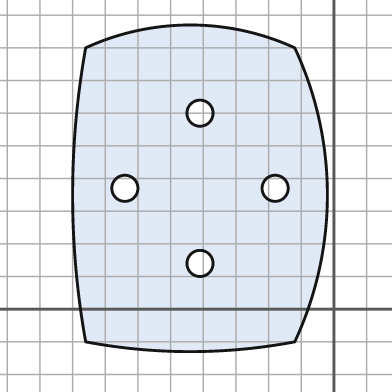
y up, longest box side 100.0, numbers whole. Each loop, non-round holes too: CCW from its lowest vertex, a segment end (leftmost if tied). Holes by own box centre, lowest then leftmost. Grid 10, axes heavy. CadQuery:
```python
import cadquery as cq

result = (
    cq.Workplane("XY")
    .moveTo(-76.0, -10.0)
    .threePointArc((-44.0, -13.0), (-12.0, -10.0))
    .threePointArc((-2.0, 35.0), (-12.0, 80.0))
    .threePointArc((-44.0, 87.0), (-76.0, 80.0))
    .threePointArc((-80.0, 35.0), (-76.0, -10.0))
    .close()
    .moveTo(-41.0, 14.0)
    .circle(4.0)
    .moveTo(-64.0, 37.0)
    .circle(4.0)
    .moveTo(-18.0, 37.0)
    .circle(4.0)
    .moveTo(-41.0, 60.0)
    .circle(4.0)
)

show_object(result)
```